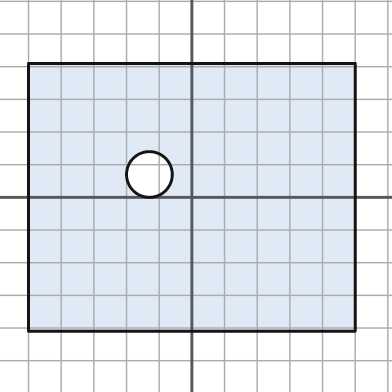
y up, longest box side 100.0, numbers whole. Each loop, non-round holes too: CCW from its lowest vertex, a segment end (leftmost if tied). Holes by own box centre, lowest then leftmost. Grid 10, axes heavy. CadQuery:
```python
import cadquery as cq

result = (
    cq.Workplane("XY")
    .moveTo(-50.0, -41.0)
    .lineTo(50.0, -41.0)
    .lineTo(50.0, 41.0)
    .lineTo(-50.0, 41.0)
    .close()
    .moveTo(-13.0, 7.0)
    .circle(7.0)
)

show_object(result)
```